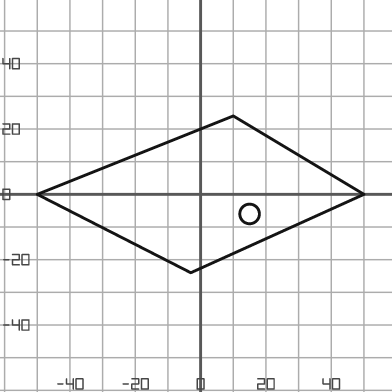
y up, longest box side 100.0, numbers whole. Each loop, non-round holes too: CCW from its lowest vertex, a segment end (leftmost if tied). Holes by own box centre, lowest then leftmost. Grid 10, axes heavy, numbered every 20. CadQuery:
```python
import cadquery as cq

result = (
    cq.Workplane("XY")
    .moveTo(-3.0, -24.0)
    .lineTo(50.0, 0.0)
    .lineTo(10.0, 24.0)
    .lineTo(-50.0, 0.0)
    .close()
    .moveTo(15.0, -6.0)
    .circle(3.0)
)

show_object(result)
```